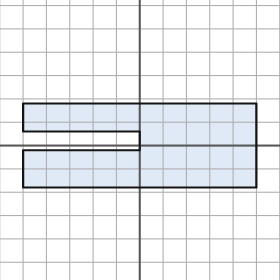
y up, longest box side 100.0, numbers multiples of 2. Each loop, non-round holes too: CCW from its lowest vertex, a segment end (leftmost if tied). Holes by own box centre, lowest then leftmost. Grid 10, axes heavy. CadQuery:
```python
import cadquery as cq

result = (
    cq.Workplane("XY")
    .moveTo(-50.0, -18.0)
    .lineTo(50.0, -18.0)
    .lineTo(50.0, 18.0)
    .lineTo(-50.0, 18.0)
    .lineTo(-50.0, 6.0)
    .lineTo(0.0, 6.0)
    .lineTo(0.0, -2.0)
    .lineTo(-50.0, -2.0)
    .close()
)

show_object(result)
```